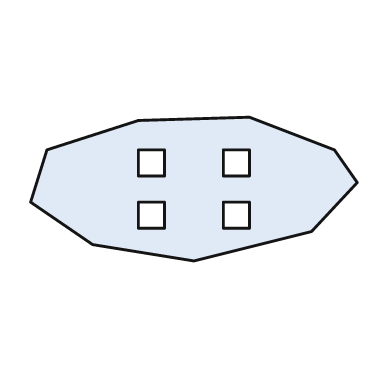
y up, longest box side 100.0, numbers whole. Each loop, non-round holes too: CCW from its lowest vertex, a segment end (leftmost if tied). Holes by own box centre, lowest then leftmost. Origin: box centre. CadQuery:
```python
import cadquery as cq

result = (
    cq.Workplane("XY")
    .moveTo(0.0, -22.0)
    .lineTo(36.0, -13.0)
    .lineTo(50.0, 2.0)
    .lineTo(43.0, 12.0)
    .lineTo(17.0, 22.0)
    .lineTo(-17.0, 21.0)
    .lineTo(-45.0, 12.0)
    .lineTo(-50.0, -4.0)
    .lineTo(-31.0, -17.0)
    .close()
    .moveTo(-17.0, -12.0)
    .lineTo(-9.0, -12.0)
    .lineTo(-9.0, -4.0)
    .lineTo(-17.0, -4.0)
    .close()
    .moveTo(9.0, -12.0)
    .lineTo(17.0, -12.0)
    .lineTo(17.0, -4.0)
    .lineTo(9.0, -4.0)
    .close()
    .moveTo(-17.0, 4.0)
    .lineTo(-9.0, 4.0)
    .lineTo(-9.0, 12.0)
    .lineTo(-17.0, 12.0)
    .close()
    .moveTo(9.0, 4.0)
    .lineTo(17.0, 4.0)
    .lineTo(17.0, 12.0)
    .lineTo(9.0, 12.0)
    .close()
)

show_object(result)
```